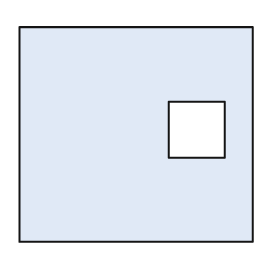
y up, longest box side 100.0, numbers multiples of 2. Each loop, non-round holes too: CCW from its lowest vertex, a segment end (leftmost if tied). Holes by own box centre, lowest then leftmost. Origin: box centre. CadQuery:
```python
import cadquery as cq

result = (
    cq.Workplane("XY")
    .moveTo(-50.0, -46.0)
    .lineTo(50.0, -46.0)
    .lineTo(50.0, 46.0)
    .lineTo(-50.0, 46.0)
    .close()
    .moveTo(14.0, -10.0)
    .lineTo(38.0, -10.0)
    .lineTo(38.0, 14.0)
    .lineTo(14.0, 14.0)
    .close()
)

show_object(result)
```